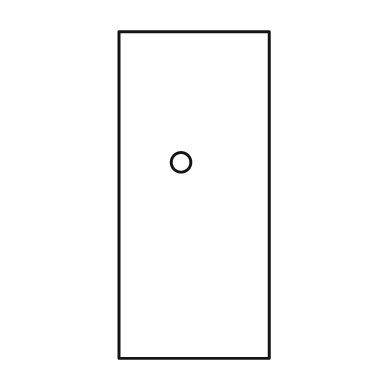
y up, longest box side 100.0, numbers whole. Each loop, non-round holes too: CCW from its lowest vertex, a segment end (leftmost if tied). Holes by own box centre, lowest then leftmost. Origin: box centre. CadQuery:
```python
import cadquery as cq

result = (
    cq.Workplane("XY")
    .moveTo(-23.0, -50.0)
    .lineTo(23.0, -50.0)
    .lineTo(23.0, 50.0)
    .lineTo(-23.0, 50.0)
    .close()
    .moveTo(-4.0, 10.0)
    .circle(3.0)
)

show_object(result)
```